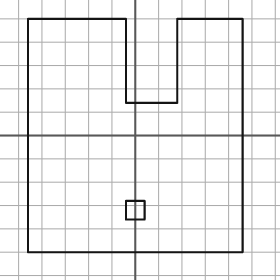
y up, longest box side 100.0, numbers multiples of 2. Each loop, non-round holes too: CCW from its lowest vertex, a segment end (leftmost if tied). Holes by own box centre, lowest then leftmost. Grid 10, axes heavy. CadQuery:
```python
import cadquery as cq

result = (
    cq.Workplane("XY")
    .moveTo(-46.0, -50.0)
    .lineTo(46.0, -50.0)
    .lineTo(46.0, 50.0)
    .lineTo(18.0, 50.0)
    .lineTo(18.0, 14.0)
    .lineTo(-4.0, 14.0)
    .lineTo(-4.0, 50.0)
    .lineTo(-46.0, 50.0)
    .close()
    .moveTo(-4.0, -36.0)
    .lineTo(4.0, -36.0)
    .lineTo(4.0, -28.0)
    .lineTo(-4.0, -28.0)
    .close()
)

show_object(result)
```